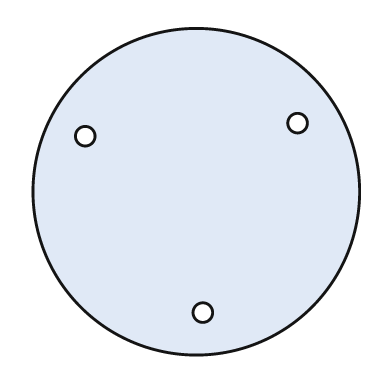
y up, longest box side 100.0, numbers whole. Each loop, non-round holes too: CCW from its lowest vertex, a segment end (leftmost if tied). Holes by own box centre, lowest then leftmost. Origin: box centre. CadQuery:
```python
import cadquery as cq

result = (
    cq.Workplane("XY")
    .moveTo(0.0, 0.0)
    .circle(50.0)
    .moveTo(2.0, -37.0)
    .circle(3.0)
    .moveTo(-34.0, 17.0)
    .circle(3.0)
    .moveTo(31.0, 21.0)
    .circle(3.0)
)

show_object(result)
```